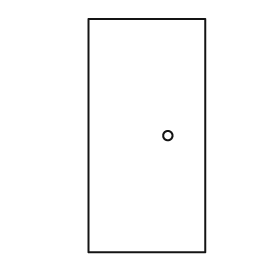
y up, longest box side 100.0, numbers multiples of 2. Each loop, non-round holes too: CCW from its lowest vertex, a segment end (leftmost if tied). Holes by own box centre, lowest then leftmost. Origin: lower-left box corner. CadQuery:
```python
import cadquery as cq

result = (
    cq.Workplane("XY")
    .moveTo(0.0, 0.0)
    .lineTo(50.0, 0.0)
    .lineTo(50.0, 100.0)
    .lineTo(0.0, 100.0)
    .close()
    .moveTo(34.0, 50.0)
    .circle(2.0)
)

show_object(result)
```